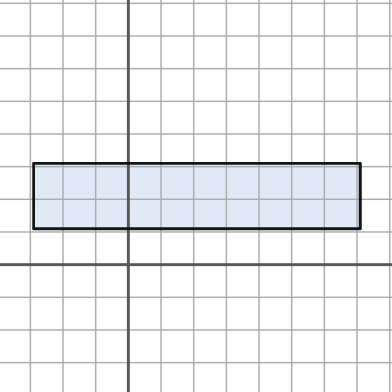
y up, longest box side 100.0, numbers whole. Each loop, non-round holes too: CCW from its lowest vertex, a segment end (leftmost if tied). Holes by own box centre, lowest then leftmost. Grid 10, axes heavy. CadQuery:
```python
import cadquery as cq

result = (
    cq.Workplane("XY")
    .moveTo(-29.0, 11.0)
    .lineTo(71.0, 11.0)
    .lineTo(71.0, 31.0)
    .lineTo(-29.0, 31.0)
    .close()
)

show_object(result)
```